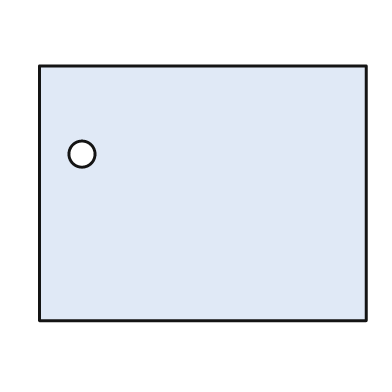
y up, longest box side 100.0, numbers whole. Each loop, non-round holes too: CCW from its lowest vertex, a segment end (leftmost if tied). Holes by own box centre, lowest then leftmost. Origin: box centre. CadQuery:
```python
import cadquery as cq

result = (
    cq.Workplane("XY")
    .moveTo(-50.0, -39.0)
    .lineTo(50.0, -39.0)
    .lineTo(50.0, 39.0)
    .lineTo(-50.0, 39.0)
    .close()
    .moveTo(-37.0, 12.0)
    .circle(4.0)
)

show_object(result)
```